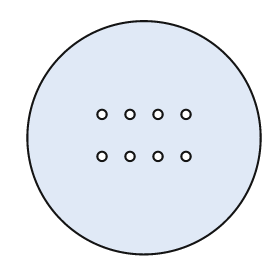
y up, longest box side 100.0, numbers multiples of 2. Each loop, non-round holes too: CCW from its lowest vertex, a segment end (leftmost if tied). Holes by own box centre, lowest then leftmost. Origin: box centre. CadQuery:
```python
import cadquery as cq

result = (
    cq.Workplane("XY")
    .moveTo(0.0, 0.0)
    .circle(50.0)
    .moveTo(-18.0, -8.0)
    .circle(2.0)
    .moveTo(-6.0, -8.0)
    .circle(2.0)
    .moveTo(6.0, -8.0)
    .circle(2.0)
    .moveTo(18.0, -8.0)
    .circle(2.0)
    .moveTo(-18.0, 10.0)
    .circle(2.0)
    .moveTo(-6.0, 10.0)
    .circle(2.0)
    .moveTo(6.0, 10.0)
    .circle(2.0)
    .moveTo(18.0, 10.0)
    .circle(2.0)
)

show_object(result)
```